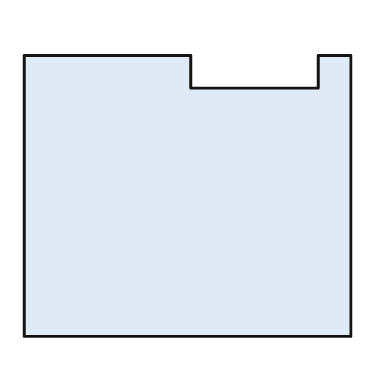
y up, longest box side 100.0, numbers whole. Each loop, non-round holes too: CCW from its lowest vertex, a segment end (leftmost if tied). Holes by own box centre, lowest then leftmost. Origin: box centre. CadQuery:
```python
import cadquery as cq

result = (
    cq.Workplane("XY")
    .moveTo(-50.0, -43.0)
    .lineTo(50.0, -43.0)
    .lineTo(50.0, 43.0)
    .lineTo(40.0, 43.0)
    .lineTo(40.0, 33.0)
    .lineTo(1.0, 33.0)
    .lineTo(1.0, 43.0)
    .lineTo(-50.0, 43.0)
    .close()
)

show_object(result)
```